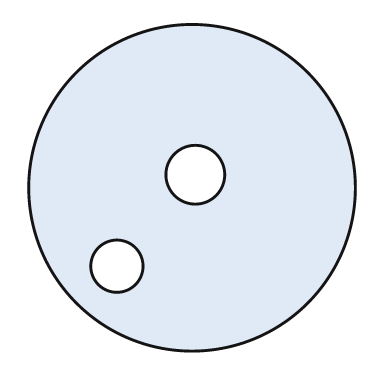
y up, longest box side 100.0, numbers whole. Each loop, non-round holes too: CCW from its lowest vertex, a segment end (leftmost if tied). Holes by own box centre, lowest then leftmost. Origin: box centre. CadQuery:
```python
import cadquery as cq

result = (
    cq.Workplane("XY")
    .moveTo(0.0, 0.0)
    .circle(50.0)
    .moveTo(-23.0, -24.0)
    .circle(8.0)
    .moveTo(1.0, 4.0)
    .circle(9.0)
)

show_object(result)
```